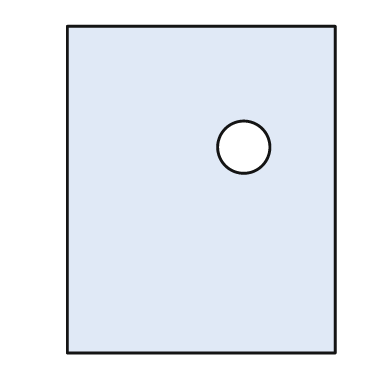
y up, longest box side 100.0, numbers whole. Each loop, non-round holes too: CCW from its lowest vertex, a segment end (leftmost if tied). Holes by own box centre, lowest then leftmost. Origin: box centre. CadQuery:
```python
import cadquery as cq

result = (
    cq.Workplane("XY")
    .moveTo(-41.0, -50.0)
    .lineTo(41.0, -50.0)
    .lineTo(41.0, 50.0)
    .lineTo(-41.0, 50.0)
    .close()
    .moveTo(13.0, 13.0)
    .circle(8.0)
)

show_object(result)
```